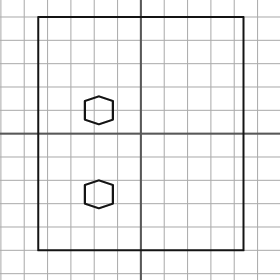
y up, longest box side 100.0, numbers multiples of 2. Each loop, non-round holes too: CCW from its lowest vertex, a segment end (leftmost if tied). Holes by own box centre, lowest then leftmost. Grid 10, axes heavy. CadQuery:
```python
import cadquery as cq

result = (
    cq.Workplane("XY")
    .moveTo(-44.0, -50.0)
    .lineTo(44.0, -50.0)
    .lineTo(44.0, 50.0)
    .lineTo(-44.0, 50.0)
    .close()
    .moveTo(-18.0, -32.0)
    .lineTo(-12.0, -30.0)
    .lineTo(-12.0, -22.0)
    .lineTo(-18.0, -20.0)
    .lineTo(-24.0, -22.0)
    .lineTo(-24.0, -30.0)
    .close()
    .moveTo(-18.0, 4.0)
    .lineTo(-12.0, 6.0)
    .lineTo(-12.0, 14.0)
    .lineTo(-18.0, 16.0)
    .lineTo(-24.0, 14.0)
    .lineTo(-24.0, 6.0)
    .close()
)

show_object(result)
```